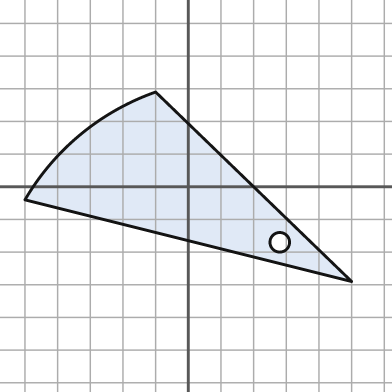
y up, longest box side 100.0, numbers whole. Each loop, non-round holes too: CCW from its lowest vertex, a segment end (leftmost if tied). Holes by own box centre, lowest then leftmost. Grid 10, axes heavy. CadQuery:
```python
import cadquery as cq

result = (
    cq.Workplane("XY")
    .moveTo(50.0, -29.0)
    .lineTo(-10.0, 29.0)
    .threePointArc((-33.0, 16.0), (-50.0, -4.0))
    .close()
    .moveTo(28.0, -17.0)
    .circle(3.0)
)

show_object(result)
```